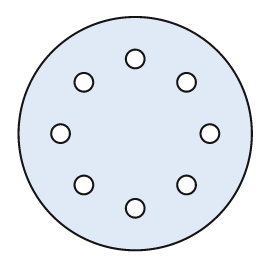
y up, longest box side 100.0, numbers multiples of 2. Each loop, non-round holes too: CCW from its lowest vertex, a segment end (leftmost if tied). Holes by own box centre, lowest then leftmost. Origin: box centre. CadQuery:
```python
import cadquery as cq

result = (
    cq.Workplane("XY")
    .moveTo(0.0, 0.0)
    .circle(50.0)
    .moveTo(0.0, -32.0)
    .circle(4.0)
    .moveTo(-22.0, -22.0)
    .circle(4.0)
    .moveTo(22.0, -22.0)
    .circle(4.0)
    .moveTo(-32.0, 0.0)
    .circle(4.0)
    .moveTo(32.0, 0.0)
    .circle(4.0)
    .moveTo(-22.0, 22.0)
    .circle(4.0)
    .moveTo(22.0, 22.0)
    .circle(4.0)
    .moveTo(0.0, 32.0)
    .circle(4.0)
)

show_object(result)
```